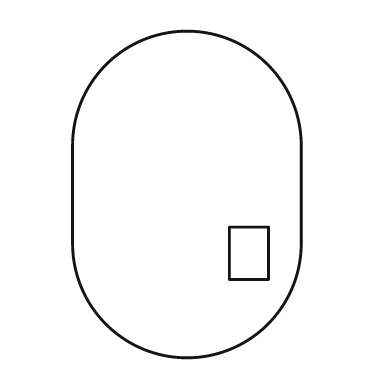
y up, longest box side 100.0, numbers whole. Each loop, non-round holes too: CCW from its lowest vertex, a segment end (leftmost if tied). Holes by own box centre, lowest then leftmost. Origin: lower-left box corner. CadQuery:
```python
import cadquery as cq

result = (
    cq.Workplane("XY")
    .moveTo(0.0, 35.0)
    .threePointArc((35.0, 0.0), (70.0, 35.0))
    .lineTo(70.0, 65.0)
    .threePointArc((35.0, 100.0), (0.0, 65.0))
    .close()
    .moveTo(48.0, 24.0)
    .lineTo(60.0, 24.0)
    .lineTo(60.0, 40.0)
    .lineTo(48.0, 40.0)
    .close()
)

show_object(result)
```